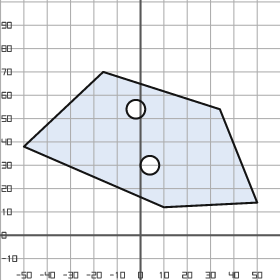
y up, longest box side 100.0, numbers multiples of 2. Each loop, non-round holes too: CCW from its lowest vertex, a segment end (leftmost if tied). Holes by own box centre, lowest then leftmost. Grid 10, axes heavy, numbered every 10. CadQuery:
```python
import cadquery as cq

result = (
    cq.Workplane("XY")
    .moveTo(10.0, 12.0)
    .lineTo(50.0, 14.0)
    .lineTo(34.0, 54.0)
    .lineTo(-16.0, 70.0)
    .lineTo(-50.0, 38.0)
    .close()
    .moveTo(4.0, 30.0)
    .circle(4.0)
    .moveTo(-2.0, 54.0)
    .circle(4.0)
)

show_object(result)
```